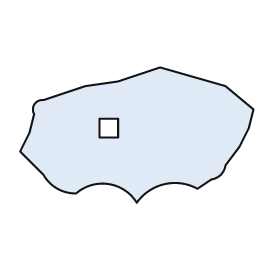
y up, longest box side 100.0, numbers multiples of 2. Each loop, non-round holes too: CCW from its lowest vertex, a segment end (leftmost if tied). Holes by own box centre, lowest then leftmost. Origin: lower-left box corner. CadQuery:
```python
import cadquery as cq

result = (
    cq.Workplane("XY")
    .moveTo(50.0, 0.0)
    .threePointArc((62.0, 8.0), (76.0, 6.0))
    .lineTo(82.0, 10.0)
    .threePointArc((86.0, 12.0), (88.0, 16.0))
    .lineTo(94.0, 24.0)
    .lineTo(98.0, 32.0)
    .lineTo(100.0, 40.0)
    .lineTo(88.0, 50.0)
    .lineTo(60.0, 58.0)
    .lineTo(42.0, 52.0)
    .lineTo(28.0, 50.0)
    .lineTo(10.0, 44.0)
    .threePointArc((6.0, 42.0), (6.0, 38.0))
    .lineTo(4.0, 30.0)
    .lineTo(0.0, 22.0)
    .lineTo(10.0, 12.0)
    .threePointArc((16.0, 6.0), (24.0, 4.0))
    .threePointArc((38.0, 8.0), (50.0, 0.0))
    .close()
    .moveTo(34.0, 28.0)
    .lineTo(42.0, 28.0)
    .lineTo(42.0, 36.0)
    .lineTo(34.0, 36.0)
    .close()
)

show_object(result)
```